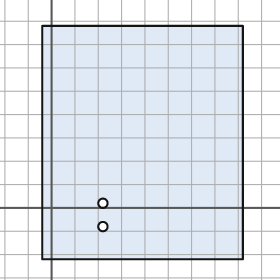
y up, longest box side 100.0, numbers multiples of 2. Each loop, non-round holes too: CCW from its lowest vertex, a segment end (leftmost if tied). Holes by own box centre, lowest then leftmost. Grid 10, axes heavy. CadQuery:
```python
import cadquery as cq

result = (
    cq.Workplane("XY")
    .moveTo(-4.0, -22.0)
    .lineTo(82.0, -22.0)
    .lineTo(82.0, 78.0)
    .lineTo(-4.0, 78.0)
    .close()
    .moveTo(22.0, -8.0)
    .circle(2.0)
    .moveTo(22.0, 2.0)
    .circle(2.0)
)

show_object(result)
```